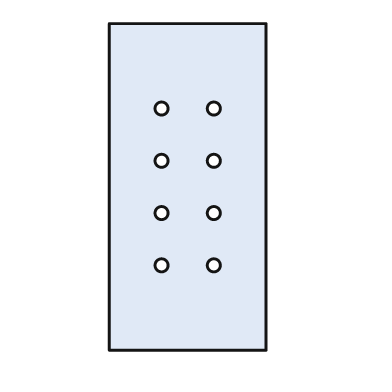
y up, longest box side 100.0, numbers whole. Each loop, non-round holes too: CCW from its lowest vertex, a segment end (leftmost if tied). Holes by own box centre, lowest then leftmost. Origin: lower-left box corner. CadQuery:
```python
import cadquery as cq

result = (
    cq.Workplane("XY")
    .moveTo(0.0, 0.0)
    .lineTo(48.0, 0.0)
    .lineTo(48.0, 100.0)
    .lineTo(0.0, 100.0)
    .close()
    .moveTo(16.0, 26.0)
    .circle(2.0)
    .moveTo(32.0, 26.0)
    .circle(2.0)
    .moveTo(16.0, 42.0)
    .circle(2.0)
    .moveTo(32.0, 42.0)
    .circle(2.0)
    .moveTo(16.0, 58.0)
    .circle(2.0)
    .moveTo(32.0, 58.0)
    .circle(2.0)
    .moveTo(16.0, 74.0)
    .circle(2.0)
    .moveTo(32.0, 74.0)
    .circle(2.0)
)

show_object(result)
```